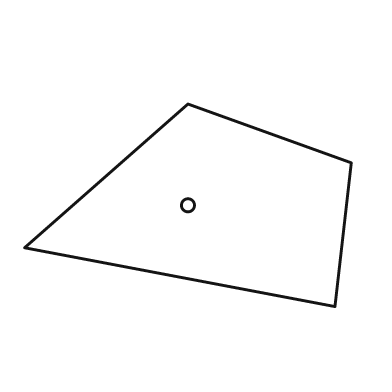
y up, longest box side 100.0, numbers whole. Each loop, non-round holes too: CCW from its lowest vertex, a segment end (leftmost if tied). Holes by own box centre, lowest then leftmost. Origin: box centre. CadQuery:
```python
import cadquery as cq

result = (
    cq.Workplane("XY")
    .moveTo(45.0, -31.0)
    .lineTo(50.0, 13.0)
    .lineTo(0.0, 31.0)
    .lineTo(-50.0, -13.0)
    .close()
    .moveTo(0.0, 0.0)
    .circle(2.0)
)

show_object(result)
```